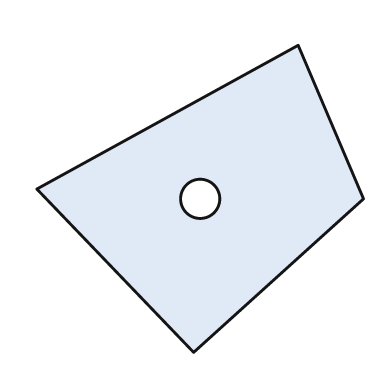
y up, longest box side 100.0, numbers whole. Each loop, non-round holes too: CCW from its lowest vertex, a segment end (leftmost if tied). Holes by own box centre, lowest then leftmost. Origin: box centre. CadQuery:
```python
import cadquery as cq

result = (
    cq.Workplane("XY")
    .moveTo(-2.0, -47.0)
    .lineTo(50.0, 0.0)
    .lineTo(30.0, 47.0)
    .lineTo(-50.0, 3.0)
    .close()
    .moveTo(0.0, 0.0)
    .circle(6.0)
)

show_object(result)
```